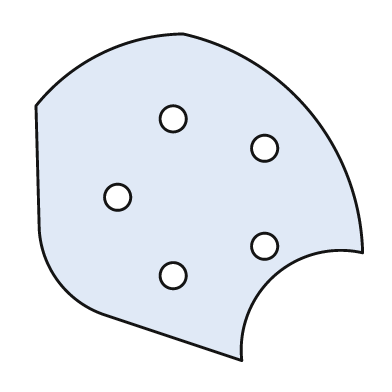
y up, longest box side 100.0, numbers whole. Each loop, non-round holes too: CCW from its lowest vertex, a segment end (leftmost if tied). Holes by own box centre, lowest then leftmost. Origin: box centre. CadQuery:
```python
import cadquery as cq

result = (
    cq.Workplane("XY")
    .moveTo(13.0, -50.0)
    .threePointArc((23.0, -24.0), (50.0, -17.0))
    .threePointArc((34.0, 26.0), (-5.0, 50.0))
    .threePointArc((-30.0, 44.0), (-50.0, 28.0))
    .lineTo(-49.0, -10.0)
    .threePointArc((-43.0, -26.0), (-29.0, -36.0))
    .close()
    .moveTo(-8.0, -24.0)
    .circle(4.0)
    .moveTo(20.0, -15.0)
    .circle(4.0)
    .moveTo(-25.0, 0.0)
    .circle(4.0)
    .moveTo(20.0, 15.0)
    .circle(4.0)
    .moveTo(-8.0, 24.0)
    .circle(4.0)
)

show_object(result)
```